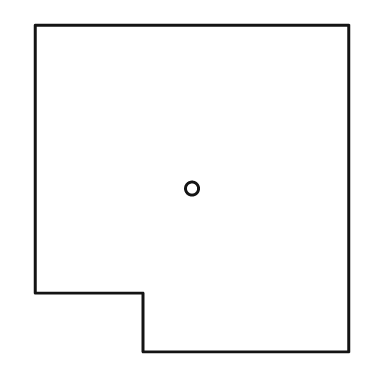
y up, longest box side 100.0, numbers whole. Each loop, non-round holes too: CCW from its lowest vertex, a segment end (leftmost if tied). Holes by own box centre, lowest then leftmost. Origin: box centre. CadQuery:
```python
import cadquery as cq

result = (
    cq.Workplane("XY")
    .moveTo(-15.0, -50.0)
    .lineTo(48.0, -50.0)
    .lineTo(48.0, 50.0)
    .lineTo(-48.0, 50.0)
    .lineTo(-48.0, -32.0)
    .lineTo(-15.0, -32.0)
    .close()
    .moveTo(0.0, 0.0)
    .circle(2.0)
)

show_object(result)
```